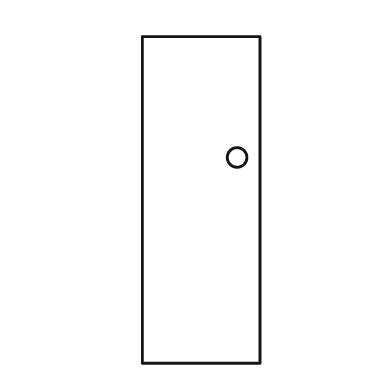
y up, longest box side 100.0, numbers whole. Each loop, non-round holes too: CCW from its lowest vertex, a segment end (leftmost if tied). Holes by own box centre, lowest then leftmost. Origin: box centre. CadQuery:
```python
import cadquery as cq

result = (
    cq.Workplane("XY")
    .moveTo(-18.0, -50.0)
    .lineTo(18.0, -50.0)
    .lineTo(18.0, 50.0)
    .lineTo(-18.0, 50.0)
    .close()
    .moveTo(11.0, 13.0)
    .circle(3.0)
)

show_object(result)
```